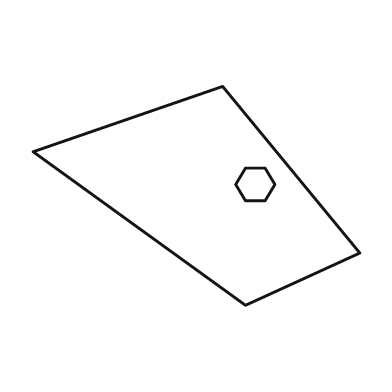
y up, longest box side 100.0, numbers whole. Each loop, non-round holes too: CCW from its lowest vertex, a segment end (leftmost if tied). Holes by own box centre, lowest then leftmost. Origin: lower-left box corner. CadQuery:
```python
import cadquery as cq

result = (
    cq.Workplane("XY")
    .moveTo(65.0, 0.0)
    .lineTo(100.0, 16.0)
    .lineTo(58.0, 67.0)
    .lineTo(0.0, 47.0)
    .close()
    .moveTo(65.0, 32.0)
    .lineTo(71.0, 32.0)
    .lineTo(74.0, 37.0)
    .lineTo(71.0, 42.0)
    .lineTo(65.0, 42.0)
    .lineTo(62.0, 37.0)
    .close()
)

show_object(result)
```